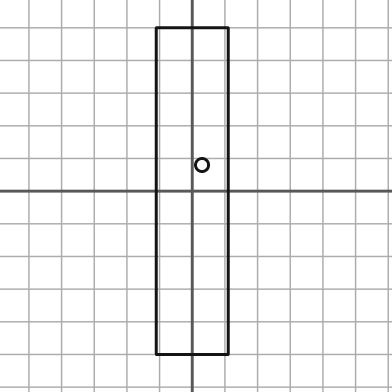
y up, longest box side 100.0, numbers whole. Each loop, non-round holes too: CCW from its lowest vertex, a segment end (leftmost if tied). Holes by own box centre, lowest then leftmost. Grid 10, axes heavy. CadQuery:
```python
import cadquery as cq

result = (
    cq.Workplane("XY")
    .moveTo(-11.0, -50.0)
    .lineTo(11.0, -50.0)
    .lineTo(11.0, 50.0)
    .lineTo(-11.0, 50.0)
    .close()
    .moveTo(3.0, 8.0)
    .circle(2.0)
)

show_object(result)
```